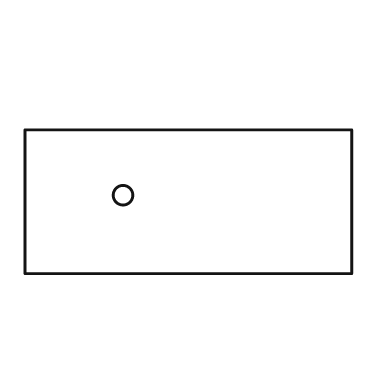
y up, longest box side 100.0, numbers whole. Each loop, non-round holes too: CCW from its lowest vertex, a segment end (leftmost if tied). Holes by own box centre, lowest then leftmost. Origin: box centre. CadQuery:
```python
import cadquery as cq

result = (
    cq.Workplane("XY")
    .moveTo(-50.0, -22.0)
    .lineTo(50.0, -22.0)
    .lineTo(50.0, 22.0)
    .lineTo(-50.0, 22.0)
    .close()
    .moveTo(-20.0, 2.0)
    .circle(3.0)
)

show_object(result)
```